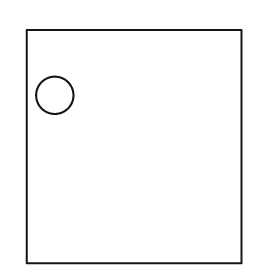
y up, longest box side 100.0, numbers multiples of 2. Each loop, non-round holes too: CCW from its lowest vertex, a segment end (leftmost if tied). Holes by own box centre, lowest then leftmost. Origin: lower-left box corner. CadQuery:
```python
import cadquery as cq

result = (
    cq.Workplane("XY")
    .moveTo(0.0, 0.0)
    .lineTo(92.0, 0.0)
    .lineTo(92.0, 100.0)
    .lineTo(0.0, 100.0)
    .close()
    .moveTo(12.0, 72.0)
    .circle(8.0)
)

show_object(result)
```